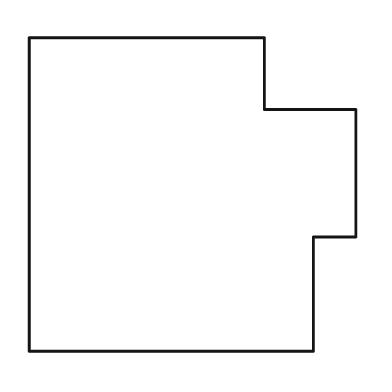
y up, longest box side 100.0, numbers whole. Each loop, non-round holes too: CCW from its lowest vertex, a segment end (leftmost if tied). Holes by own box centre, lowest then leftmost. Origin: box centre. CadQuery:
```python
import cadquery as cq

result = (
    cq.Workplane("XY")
    .moveTo(-50.0, -48.0)
    .lineTo(37.0, -48.0)
    .lineTo(37.0, -13.0)
    .lineTo(50.0, -13.0)
    .lineTo(50.0, 26.0)
    .lineTo(22.0, 26.0)
    .lineTo(22.0, 48.0)
    .lineTo(-50.0, 48.0)
    .close()
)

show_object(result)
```